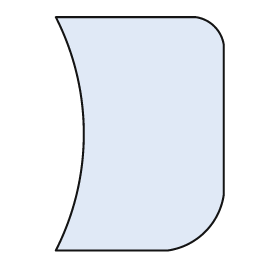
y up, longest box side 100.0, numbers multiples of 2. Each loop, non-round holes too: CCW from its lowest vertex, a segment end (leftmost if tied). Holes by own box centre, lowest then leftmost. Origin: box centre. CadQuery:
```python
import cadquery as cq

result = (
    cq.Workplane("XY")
    .moveTo(-36.0, -50.0)
    .lineTo(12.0, -50.0)
    .threePointArc((28.0, -42.0), (36.0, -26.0))
    .lineTo(36.0, 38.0)
    .threePointArc((32.0, 46.0), (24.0, 50.0))
    .lineTo(-36.0, 50.0)
    .threePointArc((-24.0, 0.0), (-36.0, -50.0))
    .close()
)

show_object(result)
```